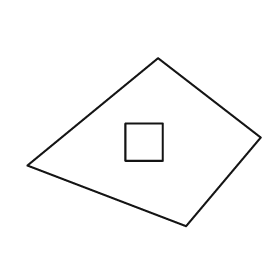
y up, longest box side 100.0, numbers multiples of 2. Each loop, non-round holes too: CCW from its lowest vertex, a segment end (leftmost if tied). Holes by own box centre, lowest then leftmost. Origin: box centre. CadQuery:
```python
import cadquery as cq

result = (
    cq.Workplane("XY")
    .moveTo(18.0, -36.0)
    .lineTo(50.0, 2.0)
    .lineTo(6.0, 36.0)
    .lineTo(-50.0, -10.0)
    .close()
    .moveTo(-8.0, -8.0)
    .lineTo(8.0, -8.0)
    .lineTo(8.0, 8.0)
    .lineTo(-8.0, 8.0)
    .close()
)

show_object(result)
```